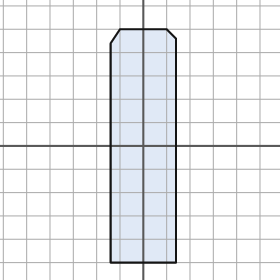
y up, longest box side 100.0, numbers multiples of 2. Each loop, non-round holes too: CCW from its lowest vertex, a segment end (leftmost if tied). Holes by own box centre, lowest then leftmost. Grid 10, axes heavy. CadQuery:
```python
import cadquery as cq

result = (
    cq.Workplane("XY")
    .moveTo(-14.0, -50.0)
    .lineTo(14.0, -50.0)
    .lineTo(14.0, 46.0)
    .lineTo(10.0, 50.0)
    .lineTo(-10.0, 50.0)
    .lineTo(-14.0, 44.0)
    .close()
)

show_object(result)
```